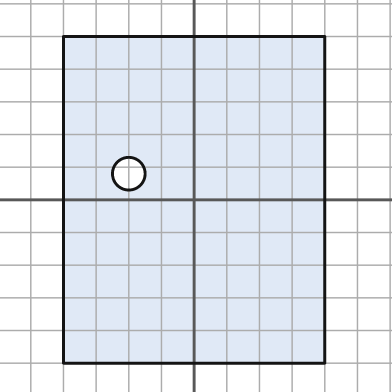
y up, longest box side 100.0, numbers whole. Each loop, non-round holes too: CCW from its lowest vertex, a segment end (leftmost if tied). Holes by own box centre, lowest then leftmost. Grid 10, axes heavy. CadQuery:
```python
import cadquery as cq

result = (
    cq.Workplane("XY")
    .moveTo(-40.0, -50.0)
    .lineTo(40.0, -50.0)
    .lineTo(40.0, 50.0)
    .lineTo(-40.0, 50.0)
    .close()
    .moveTo(-20.0, 8.0)
    .circle(5.0)
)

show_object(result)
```